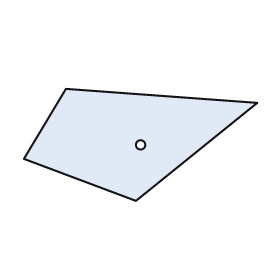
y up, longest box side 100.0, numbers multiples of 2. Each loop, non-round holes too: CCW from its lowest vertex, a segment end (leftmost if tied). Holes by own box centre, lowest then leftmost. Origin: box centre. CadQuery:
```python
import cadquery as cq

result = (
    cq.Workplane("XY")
    .moveTo(-2.0, -24.0)
    .lineTo(50.0, 18.0)
    .lineTo(-32.0, 24.0)
    .lineTo(-50.0, -6.0)
    .close()
    .moveTo(0.0, 0.0)
    .circle(2.0)
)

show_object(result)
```